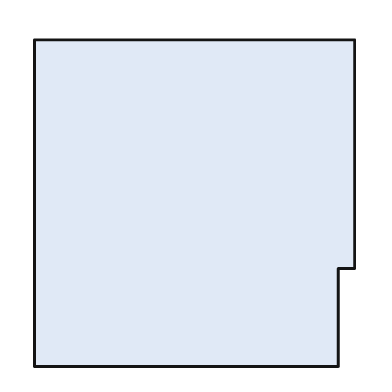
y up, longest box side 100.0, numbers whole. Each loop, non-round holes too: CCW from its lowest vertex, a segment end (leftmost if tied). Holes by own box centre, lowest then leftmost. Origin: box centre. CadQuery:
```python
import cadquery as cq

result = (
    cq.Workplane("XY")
    .moveTo(-49.0, -50.0)
    .lineTo(44.0, -50.0)
    .lineTo(44.0, -20.0)
    .lineTo(49.0, -20.0)
    .lineTo(49.0, 50.0)
    .lineTo(-49.0, 50.0)
    .close()
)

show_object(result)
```